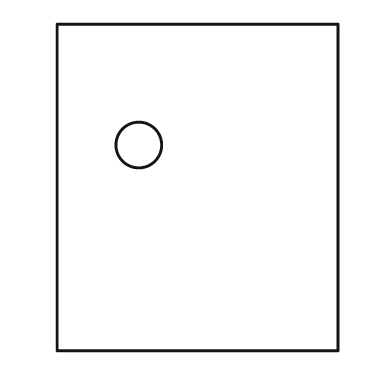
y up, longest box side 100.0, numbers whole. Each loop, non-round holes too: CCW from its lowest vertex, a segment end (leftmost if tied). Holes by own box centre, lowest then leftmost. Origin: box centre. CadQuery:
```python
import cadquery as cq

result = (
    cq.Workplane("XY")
    .moveTo(-43.0, -50.0)
    .lineTo(43.0, -50.0)
    .lineTo(43.0, 50.0)
    .lineTo(-43.0, 50.0)
    .close()
    .moveTo(-18.0, 13.0)
    .circle(7.0)
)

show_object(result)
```